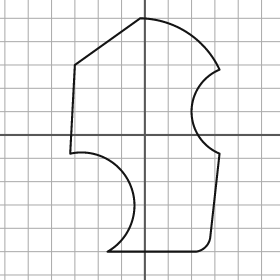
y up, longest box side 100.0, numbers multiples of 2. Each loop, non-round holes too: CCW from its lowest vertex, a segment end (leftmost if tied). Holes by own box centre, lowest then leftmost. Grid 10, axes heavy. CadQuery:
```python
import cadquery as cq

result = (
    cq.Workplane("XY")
    .moveTo(-16.0, -50.0)
    .lineTo(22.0, -50.0)
    .threePointArc((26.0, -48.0), (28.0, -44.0))
    .lineTo(32.0, -8.0)
    .threePointArc((20.0, 10.0), (32.0, 28.0))
    .threePointArc((18.0, 44.0), (-2.0, 50.0))
    .lineTo(-30.0, 30.0)
    .lineTo(-32.0, -8.0)
    .threePointArc((-6.0, -22.0), (-16.0, -50.0))
    .close()
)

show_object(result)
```